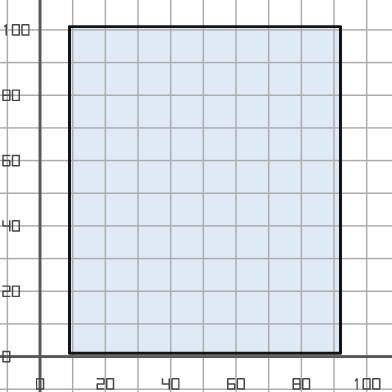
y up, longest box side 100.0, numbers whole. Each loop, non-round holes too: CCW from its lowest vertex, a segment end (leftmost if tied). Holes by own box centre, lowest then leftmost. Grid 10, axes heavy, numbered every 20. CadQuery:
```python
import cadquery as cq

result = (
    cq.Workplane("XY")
    .moveTo(9.0, 1.0)
    .lineTo(92.0, 1.0)
    .lineTo(92.0, 101.0)
    .lineTo(9.0, 101.0)
    .close()
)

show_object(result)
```